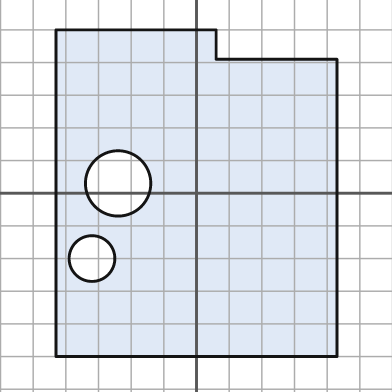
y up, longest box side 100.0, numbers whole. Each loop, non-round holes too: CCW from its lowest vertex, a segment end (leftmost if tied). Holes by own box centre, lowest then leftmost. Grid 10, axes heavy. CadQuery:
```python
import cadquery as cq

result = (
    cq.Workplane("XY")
    .moveTo(-43.0, -50.0)
    .lineTo(43.0, -50.0)
    .lineTo(43.0, 41.0)
    .lineTo(6.0, 41.0)
    .lineTo(6.0, 50.0)
    .lineTo(-43.0, 50.0)
    .close()
    .moveTo(-32.0, -20.0)
    .circle(7.0)
    .moveTo(-24.0, 3.0)
    .circle(10.0)
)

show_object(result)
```